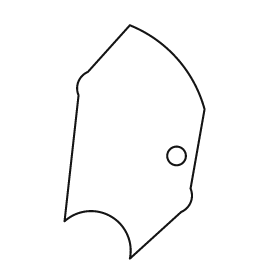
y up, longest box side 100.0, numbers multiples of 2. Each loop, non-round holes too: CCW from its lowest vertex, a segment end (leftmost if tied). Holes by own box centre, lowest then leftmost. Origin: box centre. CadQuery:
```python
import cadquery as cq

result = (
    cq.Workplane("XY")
    .moveTo(-2.0, -50.0)
    .lineTo(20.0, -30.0)
    .threePointArc((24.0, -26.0), (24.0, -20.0))
    .lineTo(30.0, 14.0)
    .threePointArc((18.0, 36.0), (-2.0, 50.0))
    .lineTo(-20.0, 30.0)
    .threePointArc((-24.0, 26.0), (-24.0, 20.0))
    .lineTo(-30.0, -34.0)
    .threePointArc((-10.0, -32.0), (-2.0, -50.0))
    .close()
    .moveTo(18.0, -6.0)
    .circle(4.0)
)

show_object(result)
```